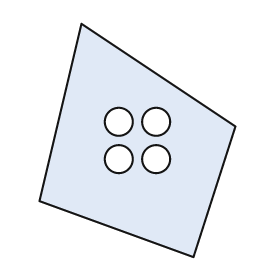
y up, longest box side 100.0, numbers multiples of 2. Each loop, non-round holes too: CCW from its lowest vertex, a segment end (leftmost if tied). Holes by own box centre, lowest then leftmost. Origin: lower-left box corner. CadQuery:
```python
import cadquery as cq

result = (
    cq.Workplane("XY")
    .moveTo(66.0, 0.0)
    .lineTo(84.0, 56.0)
    .lineTo(18.0, 100.0)
    .lineTo(0.0, 24.0)
    .close()
    .moveTo(34.0, 42.0)
    .circle(6.0)
    .moveTo(50.0, 42.0)
    .circle(6.0)
    .moveTo(34.0, 58.0)
    .circle(6.0)
    .moveTo(50.0, 58.0)
    .circle(6.0)
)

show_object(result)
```